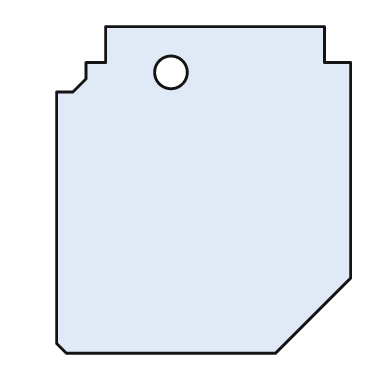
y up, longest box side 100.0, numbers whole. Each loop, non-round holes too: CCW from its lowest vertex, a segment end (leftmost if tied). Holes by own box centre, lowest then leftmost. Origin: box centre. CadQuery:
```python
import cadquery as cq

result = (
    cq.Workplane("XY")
    .moveTo(-42.0, -50.0)
    .lineTo(22.0, -50.0)
    .lineTo(45.0, -27.0)
    .lineTo(45.0, 39.0)
    .lineTo(37.0, 39.0)
    .lineTo(37.0, 50.0)
    .lineTo(-30.0, 50.0)
    .lineTo(-30.0, 39.0)
    .lineTo(-36.0, 39.0)
    .lineTo(-36.0, 34.0)
    .lineTo(-40.0, 30.0)
    .lineTo(-45.0, 30.0)
    .lineTo(-45.0, -47.0)
    .close()
    .moveTo(-10.0, 36.0)
    .circle(5.0)
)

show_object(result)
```